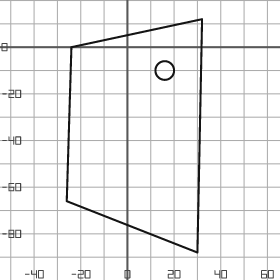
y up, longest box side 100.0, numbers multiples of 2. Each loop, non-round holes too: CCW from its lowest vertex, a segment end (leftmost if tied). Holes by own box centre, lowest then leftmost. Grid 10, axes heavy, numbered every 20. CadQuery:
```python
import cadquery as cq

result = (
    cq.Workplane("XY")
    .moveTo(30.0, -88.0)
    .lineTo(32.0, 12.0)
    .lineTo(-24.0, 0.0)
    .lineTo(-26.0, -66.0)
    .close()
    .moveTo(16.0, -10.0)
    .circle(4.0)
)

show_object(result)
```